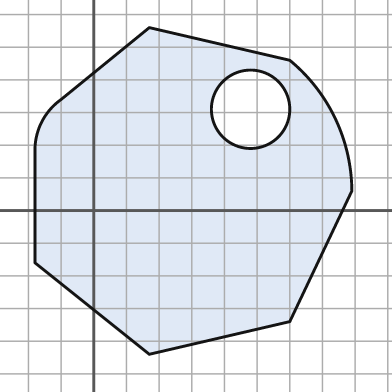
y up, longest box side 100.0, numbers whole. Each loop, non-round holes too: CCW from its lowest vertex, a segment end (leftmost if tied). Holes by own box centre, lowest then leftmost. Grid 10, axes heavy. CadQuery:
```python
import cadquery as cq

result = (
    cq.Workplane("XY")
    .moveTo(17.0, -44.0)
    .lineTo(60.0, -34.0)
    .lineTo(79.0, 6.0)
    .threePointArc((74.0, 28.0), (60.0, 46.0))
    .lineTo(17.0, 56.0)
    .lineTo(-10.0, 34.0)
    .threePointArc((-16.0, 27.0), (-18.0, 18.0))
    .lineTo(-18.0, -16.0)
    .close()
    .moveTo(48.0, 31.0)
    .circle(12.0)
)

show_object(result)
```